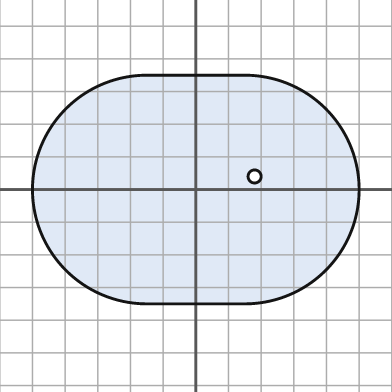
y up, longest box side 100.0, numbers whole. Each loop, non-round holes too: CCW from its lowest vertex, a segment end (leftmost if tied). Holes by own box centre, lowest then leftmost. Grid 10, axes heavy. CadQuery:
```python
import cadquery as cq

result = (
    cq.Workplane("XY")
    .moveTo(-15.0, -35.0)
    .lineTo(15.0, -35.0)
    .threePointArc((50.0, 0.0), (15.0, 35.0))
    .lineTo(-15.0, 35.0)
    .threePointArc((-50.0, 0.0), (-15.0, -35.0))
    .close()
    .moveTo(18.0, 4.0)
    .circle(2.0)
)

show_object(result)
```